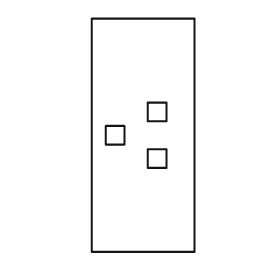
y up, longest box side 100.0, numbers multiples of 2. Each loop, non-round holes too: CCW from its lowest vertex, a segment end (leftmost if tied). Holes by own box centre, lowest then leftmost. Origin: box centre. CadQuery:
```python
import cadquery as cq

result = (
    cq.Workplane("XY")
    .moveTo(-22.0, -50.0)
    .lineTo(22.0, -50.0)
    .lineTo(22.0, 50.0)
    .lineTo(-22.0, 50.0)
    .close()
    .moveTo(2.0, -14.0)
    .lineTo(10.0, -14.0)
    .lineTo(10.0, -6.0)
    .lineTo(2.0, -6.0)
    .close()
    .moveTo(-16.0, -4.0)
    .lineTo(-8.0, -4.0)
    .lineTo(-8.0, 4.0)
    .lineTo(-16.0, 4.0)
    .close()
    .moveTo(2.0, 6.0)
    .lineTo(10.0, 6.0)
    .lineTo(10.0, 14.0)
    .lineTo(2.0, 14.0)
    .close()
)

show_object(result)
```